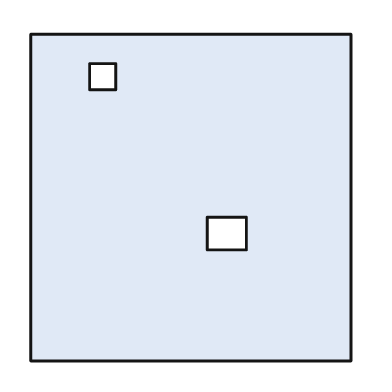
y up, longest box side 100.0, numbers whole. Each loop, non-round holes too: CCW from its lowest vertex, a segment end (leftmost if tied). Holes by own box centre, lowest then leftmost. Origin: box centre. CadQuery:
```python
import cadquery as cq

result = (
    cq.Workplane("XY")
    .moveTo(-49.0, -50.0)
    .lineTo(49.0, -50.0)
    .lineTo(49.0, 50.0)
    .lineTo(-49.0, 50.0)
    .close()
    .moveTo(5.0, -16.0)
    .lineTo(17.0, -16.0)
    .lineTo(17.0, -6.0)
    .lineTo(5.0, -6.0)
    .close()
    .moveTo(-31.0, 33.0)
    .lineTo(-23.0, 33.0)
    .lineTo(-23.0, 41.0)
    .lineTo(-31.0, 41.0)
    .close()
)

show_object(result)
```